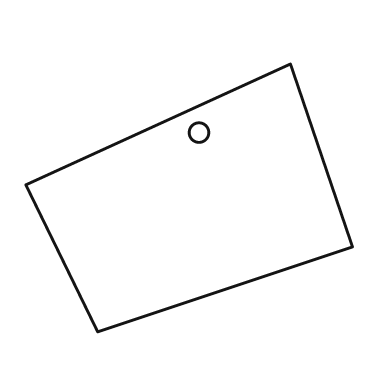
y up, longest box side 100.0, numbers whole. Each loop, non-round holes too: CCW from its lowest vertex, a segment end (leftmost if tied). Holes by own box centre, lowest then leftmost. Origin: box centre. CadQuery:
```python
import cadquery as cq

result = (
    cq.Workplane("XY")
    .moveTo(-28.0, -41.0)
    .lineTo(50.0, -15.0)
    .lineTo(31.0, 41.0)
    .lineTo(-50.0, 4.0)
    .close()
    .moveTo(3.0, 20.0)
    .circle(3.0)
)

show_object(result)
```